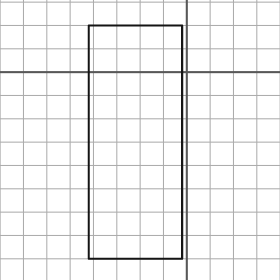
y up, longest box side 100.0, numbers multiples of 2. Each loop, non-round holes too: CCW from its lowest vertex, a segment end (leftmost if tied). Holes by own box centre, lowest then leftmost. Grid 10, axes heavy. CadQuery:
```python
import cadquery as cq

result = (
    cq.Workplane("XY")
    .moveTo(-42.0, -80.0)
    .lineTo(-2.0, -80.0)
    .lineTo(-2.0, 20.0)
    .lineTo(-42.0, 20.0)
    .close()
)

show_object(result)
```